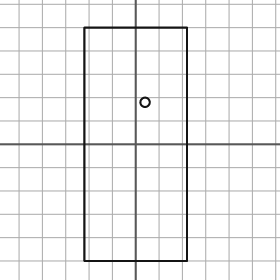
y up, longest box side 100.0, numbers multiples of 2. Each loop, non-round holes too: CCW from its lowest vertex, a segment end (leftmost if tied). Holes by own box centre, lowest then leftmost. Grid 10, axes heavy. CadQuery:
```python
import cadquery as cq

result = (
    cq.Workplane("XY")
    .moveTo(-22.0, -50.0)
    .lineTo(22.0, -50.0)
    .lineTo(22.0, 50.0)
    .lineTo(-22.0, 50.0)
    .close()
    .moveTo(4.0, 18.0)
    .circle(2.0)
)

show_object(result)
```